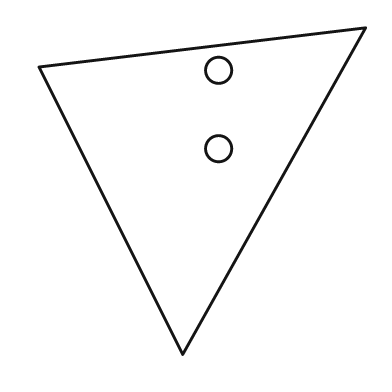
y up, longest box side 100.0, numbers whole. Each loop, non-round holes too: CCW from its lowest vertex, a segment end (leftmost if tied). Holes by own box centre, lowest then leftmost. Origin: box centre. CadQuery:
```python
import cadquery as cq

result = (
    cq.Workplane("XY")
    .moveTo(-6.0, -50.0)
    .lineTo(50.0, 50.0)
    .lineTo(-50.0, 38.0)
    .close()
    .moveTo(5.0, 13.0)
    .circle(4.0)
    .moveTo(5.0, 37.0)
    .circle(4.0)
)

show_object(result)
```